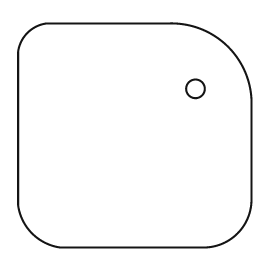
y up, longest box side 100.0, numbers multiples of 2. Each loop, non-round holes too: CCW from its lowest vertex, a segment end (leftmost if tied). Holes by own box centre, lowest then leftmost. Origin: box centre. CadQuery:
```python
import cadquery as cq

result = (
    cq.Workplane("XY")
    .moveTo(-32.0, -48.0)
    .lineTo(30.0, -48.0)
    .threePointArc((44.0, -42.0), (50.0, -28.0))
    .lineTo(50.0, 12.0)
    .threePointArc((40.0, 38.0), (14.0, 48.0))
    .lineTo(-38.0, 48.0)
    .threePointArc((-46.0, 44.0), (-50.0, 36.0))
    .lineTo(-50.0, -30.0)
    .threePointArc((-44.0, -42.0), (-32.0, -48.0))
    .close()
    .moveTo(26.0, 20.0)
    .circle(4.0)
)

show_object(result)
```